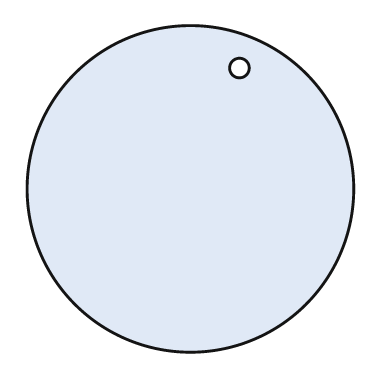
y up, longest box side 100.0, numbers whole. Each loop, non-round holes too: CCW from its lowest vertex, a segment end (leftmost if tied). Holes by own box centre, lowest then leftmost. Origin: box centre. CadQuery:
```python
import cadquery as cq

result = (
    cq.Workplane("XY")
    .moveTo(0.0, 0.0)
    .circle(50.0)
    .moveTo(15.0, 37.0)
    .circle(3.0)
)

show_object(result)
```